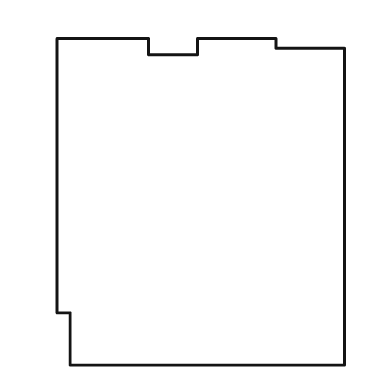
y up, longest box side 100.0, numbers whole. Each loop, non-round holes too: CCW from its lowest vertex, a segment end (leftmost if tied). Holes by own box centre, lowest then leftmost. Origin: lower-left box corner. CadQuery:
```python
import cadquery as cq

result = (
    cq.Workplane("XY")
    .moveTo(4.0, 0.0)
    .lineTo(88.0, 0.0)
    .lineTo(88.0, 97.0)
    .lineTo(67.0, 97.0)
    .lineTo(67.0, 100.0)
    .lineTo(43.0, 100.0)
    .lineTo(43.0, 95.0)
    .lineTo(28.0, 95.0)
    .lineTo(28.0, 100.0)
    .lineTo(0.0, 100.0)
    .lineTo(0.0, 16.0)
    .lineTo(4.0, 16.0)
    .close()
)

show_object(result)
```